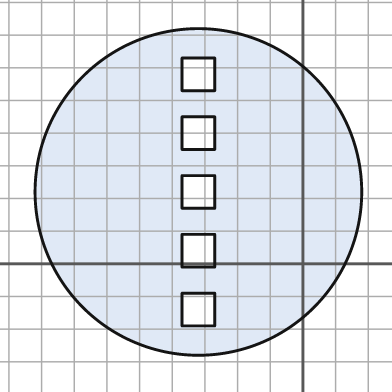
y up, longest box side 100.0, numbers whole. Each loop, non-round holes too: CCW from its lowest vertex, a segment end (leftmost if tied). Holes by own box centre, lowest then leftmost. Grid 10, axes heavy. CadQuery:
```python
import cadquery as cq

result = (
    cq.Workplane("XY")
    .moveTo(-32.0, 22.0)
    .circle(50.0)
    .moveTo(-37.0, -19.0)
    .lineTo(-27.0, -19.0)
    .lineTo(-27.0, -9.0)
    .lineTo(-37.0, -9.0)
    .close()
    .moveTo(-37.0, -1.0)
    .lineTo(-27.0, -1.0)
    .lineTo(-27.0, 9.0)
    .lineTo(-37.0, 9.0)
    .close()
    .moveTo(-37.0, 17.0)
    .lineTo(-27.0, 17.0)
    .lineTo(-27.0, 27.0)
    .lineTo(-37.0, 27.0)
    .close()
    .moveTo(-37.0, 35.0)
    .lineTo(-27.0, 35.0)
    .lineTo(-27.0, 45.0)
    .lineTo(-37.0, 45.0)
    .close()
    .moveTo(-37.0, 53.0)
    .lineTo(-27.0, 53.0)
    .lineTo(-27.0, 63.0)
    .lineTo(-37.0, 63.0)
    .close()
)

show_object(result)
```